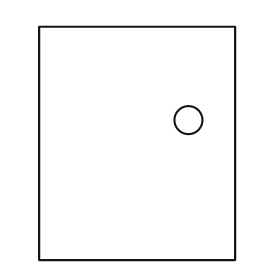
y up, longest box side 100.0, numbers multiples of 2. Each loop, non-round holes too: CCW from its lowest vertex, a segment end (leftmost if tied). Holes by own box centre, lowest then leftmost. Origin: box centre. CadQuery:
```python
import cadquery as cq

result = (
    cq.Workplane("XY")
    .moveTo(-42.0, -50.0)
    .lineTo(42.0, -50.0)
    .lineTo(42.0, 50.0)
    .lineTo(-42.0, 50.0)
    .close()
    .moveTo(22.0, 10.0)
    .circle(6.0)
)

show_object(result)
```